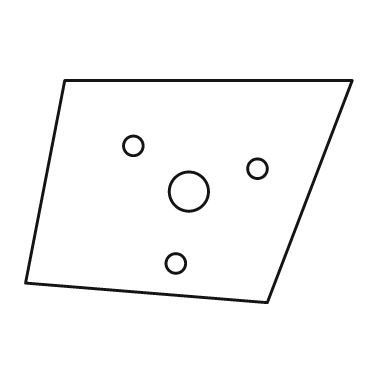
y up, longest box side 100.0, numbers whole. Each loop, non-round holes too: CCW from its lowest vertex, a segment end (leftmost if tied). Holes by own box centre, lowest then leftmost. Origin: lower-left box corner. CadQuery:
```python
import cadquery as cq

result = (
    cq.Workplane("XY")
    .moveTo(74.0, 0.0)
    .lineTo(100.0, 68.0)
    .lineTo(12.0, 68.0)
    .lineTo(0.0, 6.0)
    .close()
    .moveTo(46.0, 12.0)
    .circle(3.0)
    .moveTo(50.0, 34.0)
    .circle(6.0)
    .moveTo(71.0, 41.0)
    .circle(3.0)
    .moveTo(33.0, 48.0)
    .circle(3.0)
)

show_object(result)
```